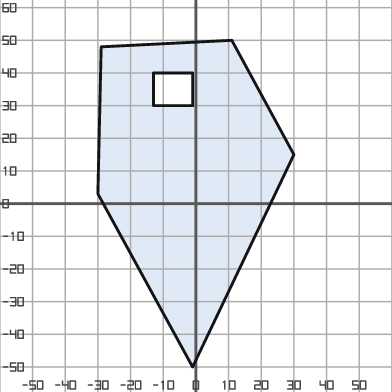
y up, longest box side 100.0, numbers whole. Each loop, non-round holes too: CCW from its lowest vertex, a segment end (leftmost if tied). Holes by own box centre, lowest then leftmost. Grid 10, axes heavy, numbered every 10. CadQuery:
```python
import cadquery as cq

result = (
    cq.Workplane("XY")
    .moveTo(-1.0, -50.0)
    .lineTo(30.0, 15.0)
    .lineTo(11.0, 50.0)
    .lineTo(-29.0, 48.0)
    .lineTo(-30.0, 3.0)
    .close()
    .moveTo(-13.0, 30.0)
    .lineTo(-1.0, 30.0)
    .lineTo(-1.0, 40.0)
    .lineTo(-13.0, 40.0)
    .close()
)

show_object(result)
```